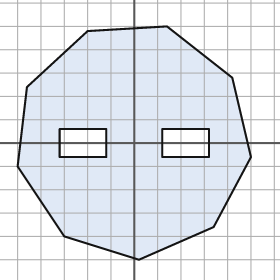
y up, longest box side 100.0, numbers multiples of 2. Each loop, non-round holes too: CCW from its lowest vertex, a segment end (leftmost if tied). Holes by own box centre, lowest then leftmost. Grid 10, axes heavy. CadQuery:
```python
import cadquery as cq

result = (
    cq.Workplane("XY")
    .moveTo(2.0, -50.0)
    .lineTo(34.0, -36.0)
    .lineTo(50.0, -6.0)
    .lineTo(42.0, 28.0)
    .lineTo(14.0, 50.0)
    .lineTo(-20.0, 48.0)
    .lineTo(-46.0, 24.0)
    .lineTo(-50.0, -10.0)
    .lineTo(-30.0, -40.0)
    .close()
    .moveTo(-32.0, -6.0)
    .lineTo(-12.0, -6.0)
    .lineTo(-12.0, 6.0)
    .lineTo(-32.0, 6.0)
    .close()
    .moveTo(12.0, -6.0)
    .lineTo(32.0, -6.0)
    .lineTo(32.0, 6.0)
    .lineTo(12.0, 6.0)
    .close()
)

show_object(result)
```